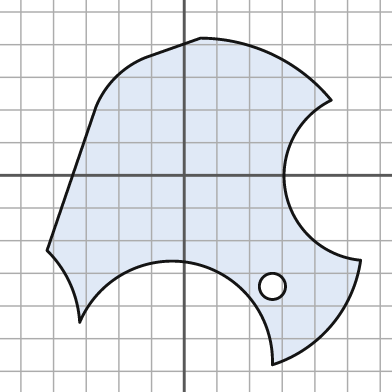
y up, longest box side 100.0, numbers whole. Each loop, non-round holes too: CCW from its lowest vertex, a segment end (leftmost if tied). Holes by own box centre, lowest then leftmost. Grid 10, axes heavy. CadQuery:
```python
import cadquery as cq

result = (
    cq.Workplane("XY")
    .moveTo(27.0, -58.0)
    .threePointArc((45.0, -46.0), (54.0, -26.0))
    .threePointArc((31.0, -5.0), (45.0, 23.0))
    .threePointArc((27.0, 37.0), (5.0, 42.0))
    .lineTo(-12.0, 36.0)
    .threePointArc((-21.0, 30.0), (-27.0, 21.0))
    .lineTo(-42.0, -23.0)
    .threePointArc((-35.0, -33.0), (-32.0, -45.0))
    .threePointArc((3.0, -27.0), (27.0, -58.0))
    .close()
    .moveTo(27.0, -34.0)
    .circle(4.0)
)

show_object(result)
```